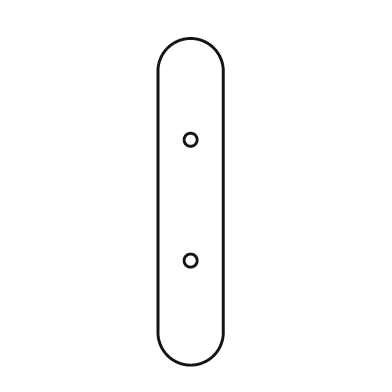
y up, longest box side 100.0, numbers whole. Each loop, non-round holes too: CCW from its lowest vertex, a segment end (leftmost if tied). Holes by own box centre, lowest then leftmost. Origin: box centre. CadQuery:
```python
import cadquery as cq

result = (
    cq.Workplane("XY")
    .moveTo(-10.0, -40.0)
    .threePointArc((0.0, -50.0), (10.0, -40.0))
    .lineTo(10.0, 40.0)
    .threePointArc((0.0, 50.0), (-10.0, 40.0))
    .close()
    .moveTo(0.0, -18.0)
    .circle(2.0)
    .moveTo(0.0, 19.0)
    .circle(2.0)
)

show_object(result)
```